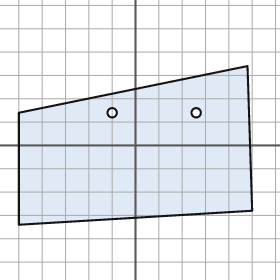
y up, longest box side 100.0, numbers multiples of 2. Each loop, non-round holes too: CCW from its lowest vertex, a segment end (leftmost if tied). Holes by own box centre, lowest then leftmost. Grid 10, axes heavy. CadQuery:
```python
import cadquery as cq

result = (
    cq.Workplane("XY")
    .moveTo(-50.0, -34.0)
    .lineTo(50.0, -28.0)
    .lineTo(48.0, 34.0)
    .lineTo(-50.0, 14.0)
    .close()
    .moveTo(-10.0, 14.0)
    .circle(2.0)
    .moveTo(26.0, 14.0)
    .circle(2.0)
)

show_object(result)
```